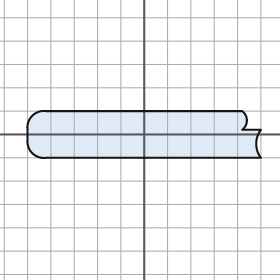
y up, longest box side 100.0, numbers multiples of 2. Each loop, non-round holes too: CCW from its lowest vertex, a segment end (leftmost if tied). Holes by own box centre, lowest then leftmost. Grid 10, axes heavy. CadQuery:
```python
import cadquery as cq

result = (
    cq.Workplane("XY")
    .moveTo(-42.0, -10.0)
    .lineTo(50.0, -10.0)
    .threePointArc((48.0, -4.0), (50.0, 2.0))
    .lineTo(42.0, 2.0)
    .threePointArc((44.0, 6.0), (42.0, 10.0))
    .lineTo(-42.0, 10.0)
    .threePointArc((-48.0, 8.0), (-50.0, 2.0))
    .lineTo(-50.0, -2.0)
    .threePointArc((-48.0, -8.0), (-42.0, -10.0))
    .close()
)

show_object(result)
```